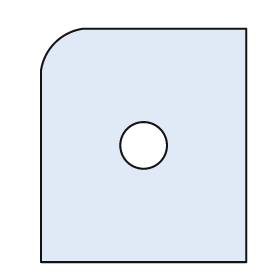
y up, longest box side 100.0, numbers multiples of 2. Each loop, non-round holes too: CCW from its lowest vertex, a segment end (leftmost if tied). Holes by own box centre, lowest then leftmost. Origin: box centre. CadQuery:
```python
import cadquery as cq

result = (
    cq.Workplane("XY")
    .moveTo(-44.0, -50.0)
    .lineTo(44.0, -50.0)
    .lineTo(44.0, 50.0)
    .lineTo(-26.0, 50.0)
    .threePointArc((-38.0, 44.0), (-44.0, 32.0))
    .close()
    .moveTo(0.0, 0.0)
    .circle(10.0)
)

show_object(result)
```